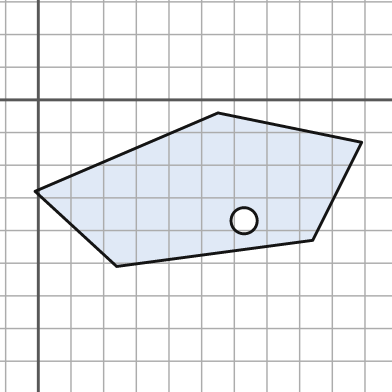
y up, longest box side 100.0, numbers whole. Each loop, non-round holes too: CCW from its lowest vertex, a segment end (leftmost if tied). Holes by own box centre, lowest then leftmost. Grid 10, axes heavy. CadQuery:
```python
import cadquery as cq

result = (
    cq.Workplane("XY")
    .moveTo(24.0, -51.0)
    .lineTo(84.0, -43.0)
    .lineTo(99.0, -13.0)
    .lineTo(55.0, -4.0)
    .lineTo(-1.0, -28.0)
    .close()
    .moveTo(63.0, -37.0)
    .circle(4.0)
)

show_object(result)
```